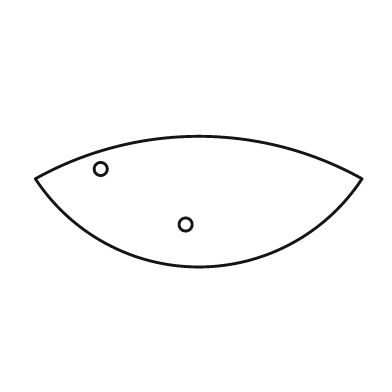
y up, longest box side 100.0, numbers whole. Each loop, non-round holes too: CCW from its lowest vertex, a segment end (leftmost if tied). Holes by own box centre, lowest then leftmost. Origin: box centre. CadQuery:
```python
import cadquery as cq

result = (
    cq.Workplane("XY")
    .moveTo(-50.0, 7.0)
    .threePointArc((0.0, -20.0), (50.0, 7.0))
    .threePointArc((0.0, 20.0), (-50.0, 7.0))
    .close()
    .moveTo(-4.0, -7.0)
    .circle(2.0)
    .moveTo(-30.0, 10.0)
    .circle(2.0)
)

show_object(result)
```